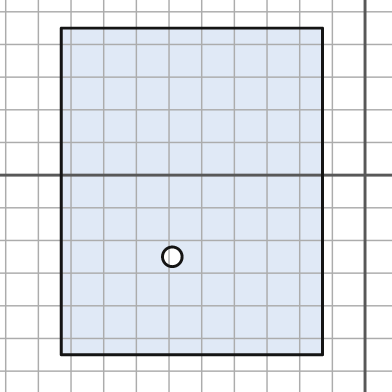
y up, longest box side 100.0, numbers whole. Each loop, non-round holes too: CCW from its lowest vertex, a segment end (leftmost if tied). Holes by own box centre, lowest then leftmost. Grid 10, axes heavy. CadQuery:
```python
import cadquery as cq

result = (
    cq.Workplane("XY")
    .moveTo(-93.0, -55.0)
    .lineTo(-13.0, -55.0)
    .lineTo(-13.0, 45.0)
    .lineTo(-93.0, 45.0)
    .close()
    .moveTo(-59.0, -25.0)
    .circle(3.0)
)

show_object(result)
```